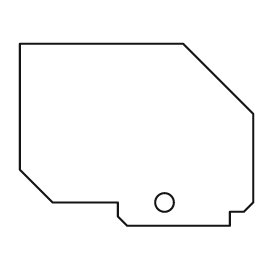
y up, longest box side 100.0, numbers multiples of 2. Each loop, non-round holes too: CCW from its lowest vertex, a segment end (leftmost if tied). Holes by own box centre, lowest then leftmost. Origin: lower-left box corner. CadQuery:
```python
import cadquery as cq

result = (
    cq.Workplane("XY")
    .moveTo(46.0, 0.0)
    .lineTo(90.0, 0.0)
    .lineTo(90.0, 6.0)
    .lineTo(96.0, 6.0)
    .lineTo(100.0, 10.0)
    .lineTo(100.0, 48.0)
    .lineTo(70.0, 78.0)
    .lineTo(0.0, 78.0)
    .lineTo(0.0, 24.0)
    .lineTo(14.0, 10.0)
    .lineTo(42.0, 10.0)
    .lineTo(42.0, 4.0)
    .close()
    .moveTo(62.0, 10.0)
    .circle(4.0)
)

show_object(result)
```